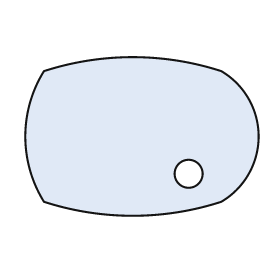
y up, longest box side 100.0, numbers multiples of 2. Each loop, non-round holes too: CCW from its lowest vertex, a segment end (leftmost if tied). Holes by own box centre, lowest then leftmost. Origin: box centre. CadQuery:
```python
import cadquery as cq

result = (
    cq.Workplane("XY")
    .moveTo(-42.0, -28.0)
    .threePointArc((-4.0, -34.0), (34.0, -28.0))
    .threePointArc((50.0, 0.0), (34.0, 28.0))
    .threePointArc((-4.0, 34.0), (-42.0, 28.0))
    .threePointArc((-50.0, 0.0), (-42.0, -28.0))
    .close()
    .moveTo(20.0, -16.0)
    .circle(6.0)
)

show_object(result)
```